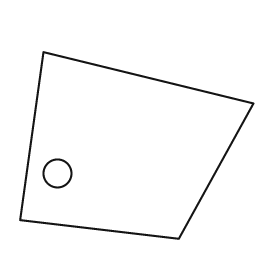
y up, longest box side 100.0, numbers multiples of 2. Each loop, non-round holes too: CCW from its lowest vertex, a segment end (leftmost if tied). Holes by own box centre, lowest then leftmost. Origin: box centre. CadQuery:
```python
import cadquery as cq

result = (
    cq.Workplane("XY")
    .moveTo(18.0, -40.0)
    .lineTo(50.0, 18.0)
    .lineTo(-40.0, 40.0)
    .lineTo(-50.0, -32.0)
    .close()
    .moveTo(-34.0, -12.0)
    .circle(6.0)
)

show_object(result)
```